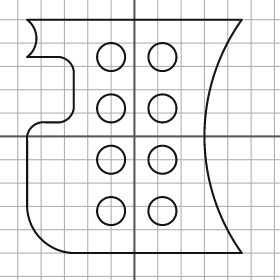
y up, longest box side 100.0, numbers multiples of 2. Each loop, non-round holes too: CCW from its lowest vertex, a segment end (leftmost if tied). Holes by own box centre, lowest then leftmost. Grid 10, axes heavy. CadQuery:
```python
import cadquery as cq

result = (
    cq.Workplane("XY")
    .moveTo(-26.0, -50.0)
    .lineTo(46.0, -50.0)
    .threePointArc((30.0, 0.0), (46.0, 50.0))
    .lineTo(-46.0, 50.0)
    .threePointArc((-42.0, 42.0), (-46.0, 34.0))
    .lineTo(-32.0, 34.0)
    .threePointArc((-28.0, 32.0), (-26.0, 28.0))
    .lineTo(-26.0, 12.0)
    .threePointArc((-28.0, 8.0), (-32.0, 6.0))
    .lineTo(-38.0, 6.0)
    .threePointArc((-44.0, 4.0), (-46.0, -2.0))
    .lineTo(-46.0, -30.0)
    .threePointArc((-40.0, -44.0), (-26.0, -50.0))
    .close()
    .moveTo(-10.0, -32.0)
    .circle(6.0)
    .moveTo(12.0, -32.0)
    .circle(6.0)
    .moveTo(-10.0, -10.0)
    .circle(6.0)
    .moveTo(12.0, -10.0)
    .circle(6.0)
    .moveTo(-10.0, 12.0)
    .circle(6.0)
    .moveTo(12.0, 12.0)
    .circle(6.0)
    .moveTo(-10.0, 34.0)
    .circle(6.0)
    .moveTo(12.0, 34.0)
    .circle(6.0)
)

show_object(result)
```